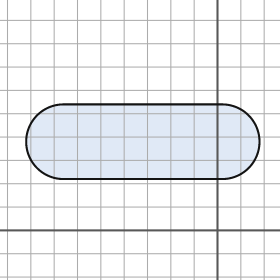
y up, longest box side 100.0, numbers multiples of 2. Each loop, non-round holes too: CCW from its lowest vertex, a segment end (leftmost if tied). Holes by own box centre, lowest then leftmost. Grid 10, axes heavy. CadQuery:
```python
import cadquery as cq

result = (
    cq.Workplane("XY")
    .moveTo(-66.0, 22.0)
    .lineTo(2.0, 22.0)
    .threePointArc((18.0, 38.0), (2.0, 54.0))
    .lineTo(-66.0, 54.0)
    .threePointArc((-82.0, 38.0), (-66.0, 22.0))
    .close()
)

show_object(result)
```